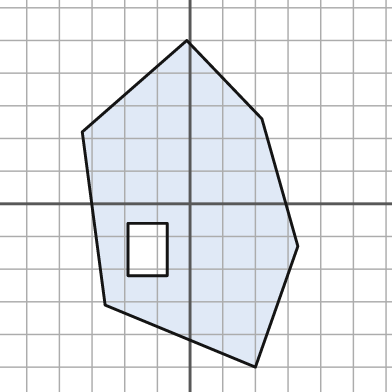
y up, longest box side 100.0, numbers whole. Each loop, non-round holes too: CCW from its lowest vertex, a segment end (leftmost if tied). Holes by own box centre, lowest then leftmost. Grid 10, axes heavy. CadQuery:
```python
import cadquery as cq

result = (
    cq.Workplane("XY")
    .moveTo(20.0, -50.0)
    .lineTo(33.0, -13.0)
    .lineTo(22.0, 26.0)
    .lineTo(-1.0, 50.0)
    .lineTo(-33.0, 22.0)
    .lineTo(-26.0, -31.0)
    .close()
    .moveTo(-19.0, -22.0)
    .lineTo(-7.0, -22.0)
    .lineTo(-7.0, -6.0)
    .lineTo(-19.0, -6.0)
    .close()
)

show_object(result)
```